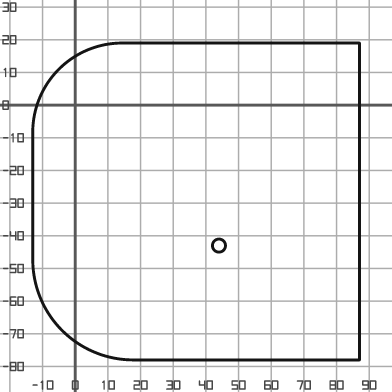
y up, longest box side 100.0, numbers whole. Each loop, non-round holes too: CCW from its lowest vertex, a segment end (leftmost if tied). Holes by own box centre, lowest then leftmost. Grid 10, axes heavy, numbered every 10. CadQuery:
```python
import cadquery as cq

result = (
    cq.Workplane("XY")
    .moveTo(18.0, -78.0)
    .lineTo(87.0, -78.0)
    .lineTo(87.0, 19.0)
    .lineTo(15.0, 19.0)
    .threePointArc((-5.0, 11.0), (-13.0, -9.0))
    .lineTo(-13.0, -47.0)
    .threePointArc((-4.0, -69.0), (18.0, -78.0))
    .close()
    .moveTo(44.0, -43.0)
    .circle(2.0)
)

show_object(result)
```